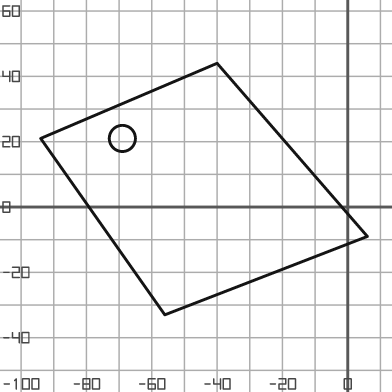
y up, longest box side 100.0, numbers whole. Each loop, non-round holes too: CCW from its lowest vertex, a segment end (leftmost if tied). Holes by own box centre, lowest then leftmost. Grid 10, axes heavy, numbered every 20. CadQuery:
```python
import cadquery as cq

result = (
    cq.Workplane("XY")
    .moveTo(-56.0, -33.0)
    .lineTo(6.0, -9.0)
    .lineTo(-40.0, 44.0)
    .lineTo(-94.0, 21.0)
    .close()
    .moveTo(-69.0, 21.0)
    .circle(4.0)
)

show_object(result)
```